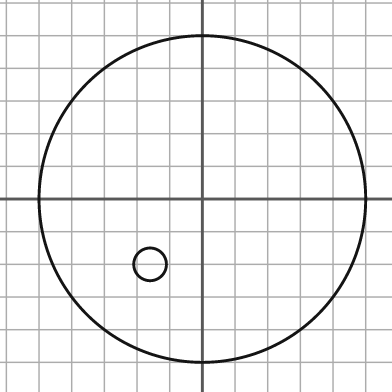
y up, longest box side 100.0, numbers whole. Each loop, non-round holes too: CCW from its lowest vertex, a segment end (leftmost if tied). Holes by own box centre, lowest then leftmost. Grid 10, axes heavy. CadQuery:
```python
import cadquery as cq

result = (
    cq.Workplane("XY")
    .moveTo(0.0, 0.0)
    .circle(50.0)
    .moveTo(-16.0, -20.0)
    .circle(5.0)
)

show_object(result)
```